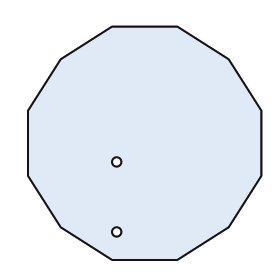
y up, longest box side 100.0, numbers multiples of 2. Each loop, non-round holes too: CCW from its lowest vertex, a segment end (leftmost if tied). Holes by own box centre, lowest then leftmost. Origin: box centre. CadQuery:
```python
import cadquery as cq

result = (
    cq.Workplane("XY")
    .moveTo(-14.0, -50.0)
    .lineTo(14.0, -50.0)
    .lineTo(36.0, -36.0)
    .lineTo(50.0, -14.0)
    .lineTo(50.0, 14.0)
    .lineTo(36.0, 36.0)
    .lineTo(14.0, 50.0)
    .lineTo(-14.0, 50.0)
    .lineTo(-36.0, 36.0)
    .lineTo(-50.0, 14.0)
    .lineTo(-50.0, -14.0)
    .lineTo(-36.0, -36.0)
    .close()
    .moveTo(-12.0, -38.0)
    .circle(2.0)
    .moveTo(-12.0, -8.0)
    .circle(2.0)
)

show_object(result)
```